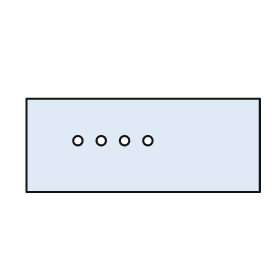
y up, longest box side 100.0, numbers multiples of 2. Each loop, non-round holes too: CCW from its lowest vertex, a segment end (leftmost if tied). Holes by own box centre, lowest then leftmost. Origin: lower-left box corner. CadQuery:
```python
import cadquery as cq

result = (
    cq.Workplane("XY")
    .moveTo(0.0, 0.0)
    .lineTo(100.0, 0.0)
    .lineTo(100.0, 40.0)
    .lineTo(0.0, 40.0)
    .close()
    .moveTo(22.0, 22.0)
    .circle(2.0)
    .moveTo(32.0, 22.0)
    .circle(2.0)
    .moveTo(42.0, 22.0)
    .circle(2.0)
    .moveTo(52.0, 22.0)
    .circle(2.0)
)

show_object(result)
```